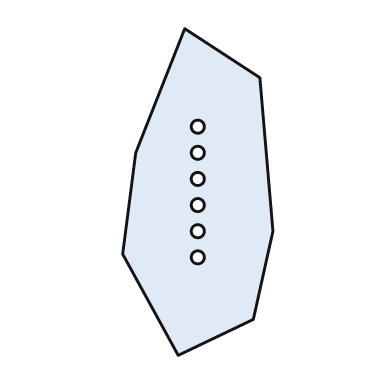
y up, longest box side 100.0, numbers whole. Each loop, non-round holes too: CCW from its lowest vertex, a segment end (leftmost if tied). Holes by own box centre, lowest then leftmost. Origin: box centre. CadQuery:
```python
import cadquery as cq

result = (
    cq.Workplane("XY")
    .moveTo(-6.0, -50.0)
    .lineTo(17.0, -39.0)
    .lineTo(23.0, -12.0)
    .lineTo(19.0, 35.0)
    .lineTo(-4.0, 50.0)
    .lineTo(-19.0, 12.0)
    .lineTo(-23.0, -19.0)
    .close()
    .moveTo(0.0, -20.0)
    .circle(2.0)
    .moveTo(0.0, -12.0)
    .circle(2.0)
    .moveTo(0.0, -4.0)
    .circle(2.0)
    .moveTo(0.0, 4.0)
    .circle(2.0)
    .moveTo(0.0, 12.0)
    .circle(2.0)
    .moveTo(0.0, 20.0)
    .circle(2.0)
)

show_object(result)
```